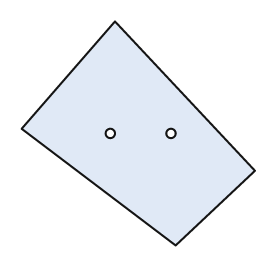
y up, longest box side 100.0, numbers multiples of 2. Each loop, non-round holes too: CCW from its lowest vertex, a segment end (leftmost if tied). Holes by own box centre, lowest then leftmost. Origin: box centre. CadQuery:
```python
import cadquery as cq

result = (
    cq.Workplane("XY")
    .moveTo(16.0, -48.0)
    .lineTo(50.0, -16.0)
    .lineTo(-10.0, 48.0)
    .lineTo(-50.0, 2.0)
    .close()
    .moveTo(-12.0, 0.0)
    .circle(2.0)
    .moveTo(14.0, 0.0)
    .circle(2.0)
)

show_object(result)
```